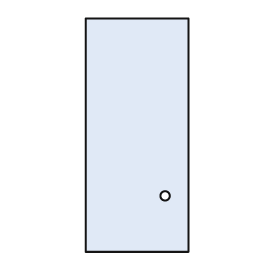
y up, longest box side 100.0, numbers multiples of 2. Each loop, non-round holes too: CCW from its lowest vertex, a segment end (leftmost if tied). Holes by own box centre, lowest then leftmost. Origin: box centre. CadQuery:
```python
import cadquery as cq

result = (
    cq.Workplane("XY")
    .moveTo(-22.0, -50.0)
    .lineTo(22.0, -50.0)
    .lineTo(22.0, 50.0)
    .lineTo(-22.0, 50.0)
    .close()
    .moveTo(12.0, -26.0)
    .circle(2.0)
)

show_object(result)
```